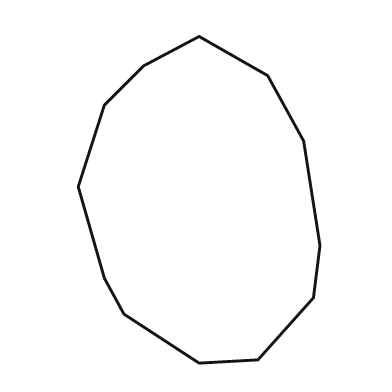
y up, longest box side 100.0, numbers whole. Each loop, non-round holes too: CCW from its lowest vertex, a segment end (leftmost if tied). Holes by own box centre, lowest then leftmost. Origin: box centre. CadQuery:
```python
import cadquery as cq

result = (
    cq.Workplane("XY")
    .moveTo(0.0, -50.0)
    .lineTo(18.0, -49.0)
    .lineTo(35.0, -30.0)
    .lineTo(37.0, -14.0)
    .lineTo(32.0, 18.0)
    .lineTo(21.0, 38.0)
    .lineTo(0.0, 50.0)
    .lineTo(-17.0, 41.0)
    .lineTo(-29.0, 29.0)
    .lineTo(-37.0, 4.0)
    .lineTo(-29.0, -24.0)
    .lineTo(-23.0, -35.0)
    .close()
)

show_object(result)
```